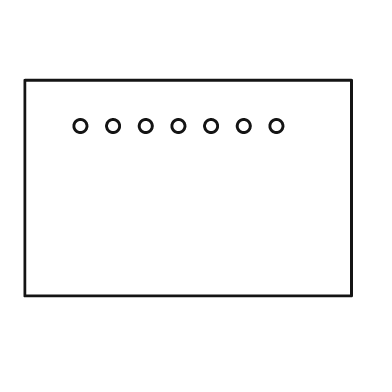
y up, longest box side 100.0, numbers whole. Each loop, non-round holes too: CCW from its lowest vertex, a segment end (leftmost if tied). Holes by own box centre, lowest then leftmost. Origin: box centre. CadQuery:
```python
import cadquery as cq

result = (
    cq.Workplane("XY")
    .moveTo(-50.0, -33.0)
    .lineTo(50.0, -33.0)
    .lineTo(50.0, 33.0)
    .lineTo(-50.0, 33.0)
    .close()
    .moveTo(-33.0, 19.0)
    .circle(2.0)
    .moveTo(-23.0, 19.0)
    .circle(2.0)
    .moveTo(-13.0, 19.0)
    .circle(2.0)
    .moveTo(-3.0, 19.0)
    .circle(2.0)
    .moveTo(7.0, 19.0)
    .circle(2.0)
    .moveTo(17.0, 19.0)
    .circle(2.0)
    .moveTo(27.0, 19.0)
    .circle(2.0)
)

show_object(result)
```